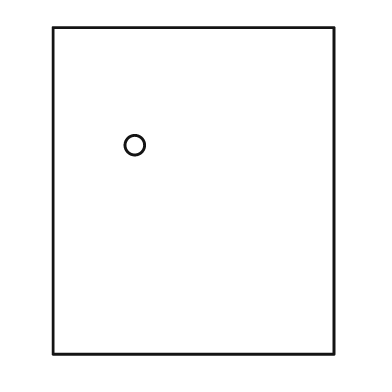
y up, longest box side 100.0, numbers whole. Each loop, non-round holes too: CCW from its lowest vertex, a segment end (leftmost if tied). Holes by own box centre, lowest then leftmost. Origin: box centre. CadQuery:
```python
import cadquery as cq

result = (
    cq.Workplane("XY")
    .moveTo(-43.0, -50.0)
    .lineTo(43.0, -50.0)
    .lineTo(43.0, 50.0)
    .lineTo(-43.0, 50.0)
    .close()
    .moveTo(-18.0, 14.0)
    .circle(3.0)
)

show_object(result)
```